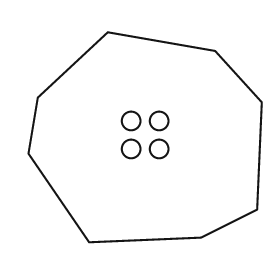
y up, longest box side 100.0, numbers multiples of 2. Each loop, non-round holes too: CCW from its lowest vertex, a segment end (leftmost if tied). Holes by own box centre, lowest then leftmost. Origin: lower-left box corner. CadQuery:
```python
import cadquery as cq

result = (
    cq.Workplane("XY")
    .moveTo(26.0, 0.0)
    .lineTo(74.0, 2.0)
    .lineTo(98.0, 14.0)
    .lineTo(100.0, 60.0)
    .lineTo(80.0, 82.0)
    .lineTo(34.0, 90.0)
    .lineTo(4.0, 62.0)
    .lineTo(0.0, 38.0)
    .close()
    .moveTo(44.0, 40.0)
    .circle(4.0)
    .moveTo(56.0, 40.0)
    .circle(4.0)
    .moveTo(44.0, 52.0)
    .circle(4.0)
    .moveTo(56.0, 52.0)
    .circle(4.0)
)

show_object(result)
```